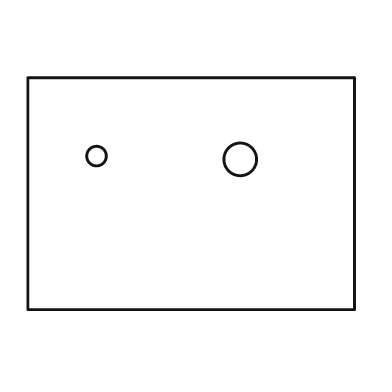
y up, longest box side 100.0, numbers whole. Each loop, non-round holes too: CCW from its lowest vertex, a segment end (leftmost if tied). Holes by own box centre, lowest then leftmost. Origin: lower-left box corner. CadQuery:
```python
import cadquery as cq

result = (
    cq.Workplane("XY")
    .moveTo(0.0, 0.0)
    .lineTo(100.0, 0.0)
    .lineTo(100.0, 71.0)
    .lineTo(0.0, 71.0)
    .close()
    .moveTo(65.0, 46.0)
    .circle(5.0)
    .moveTo(21.0, 47.0)
    .circle(3.0)
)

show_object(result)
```